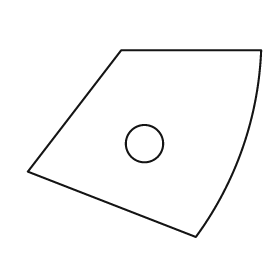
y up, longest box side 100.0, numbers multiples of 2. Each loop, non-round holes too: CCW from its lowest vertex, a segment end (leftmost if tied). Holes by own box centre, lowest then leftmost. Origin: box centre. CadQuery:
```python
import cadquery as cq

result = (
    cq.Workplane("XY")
    .moveTo(22.0, -40.0)
    .threePointArc((42.0, -2.0), (50.0, 40.0))
    .lineTo(-10.0, 40.0)
    .lineTo(-50.0, -12.0)
    .close()
    .moveTo(0.0, 0.0)
    .circle(8.0)
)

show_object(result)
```